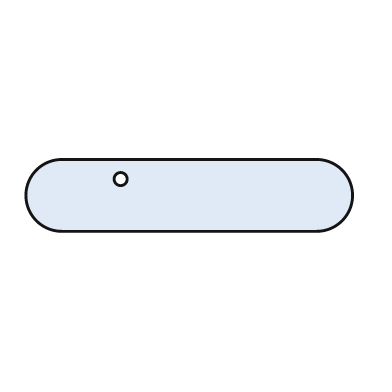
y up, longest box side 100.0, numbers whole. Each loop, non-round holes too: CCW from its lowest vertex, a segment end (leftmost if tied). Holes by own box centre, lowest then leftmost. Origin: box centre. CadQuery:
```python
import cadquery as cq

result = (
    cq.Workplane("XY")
    .moveTo(-39.0, -11.0)
    .lineTo(39.0, -11.0)
    .threePointArc((50.0, 0.0), (39.0, 11.0))
    .lineTo(-39.0, 11.0)
    .threePointArc((-50.0, 0.0), (-39.0, -11.0))
    .close()
    .moveTo(-21.0, 5.0)
    .circle(2.0)
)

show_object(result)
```